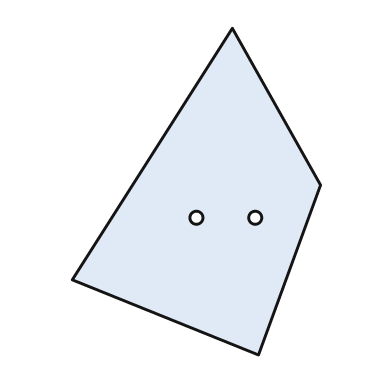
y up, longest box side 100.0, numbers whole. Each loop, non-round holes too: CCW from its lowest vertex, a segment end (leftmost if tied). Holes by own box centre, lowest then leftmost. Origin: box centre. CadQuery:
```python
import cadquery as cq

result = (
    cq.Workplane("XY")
    .moveTo(19.0, -50.0)
    .lineTo(38.0, 2.0)
    .lineTo(11.0, 50.0)
    .lineTo(-38.0, -27.0)
    .close()
    .moveTo(0.0, -8.0)
    .circle(2.0)
    .moveTo(18.0, -8.0)
    .circle(2.0)
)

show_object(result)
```